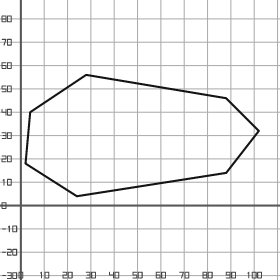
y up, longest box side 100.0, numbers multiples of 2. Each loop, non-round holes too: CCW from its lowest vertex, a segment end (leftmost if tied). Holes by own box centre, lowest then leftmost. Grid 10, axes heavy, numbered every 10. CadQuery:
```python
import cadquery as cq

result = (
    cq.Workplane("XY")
    .moveTo(24.0, 4.0)
    .lineTo(88.0, 14.0)
    .lineTo(102.0, 32.0)
    .lineTo(88.0, 46.0)
    .lineTo(28.0, 56.0)
    .lineTo(4.0, 40.0)
    .lineTo(2.0, 18.0)
    .close()
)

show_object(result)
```